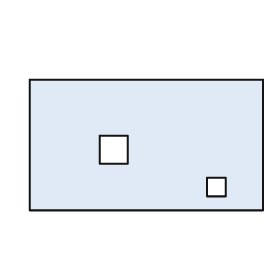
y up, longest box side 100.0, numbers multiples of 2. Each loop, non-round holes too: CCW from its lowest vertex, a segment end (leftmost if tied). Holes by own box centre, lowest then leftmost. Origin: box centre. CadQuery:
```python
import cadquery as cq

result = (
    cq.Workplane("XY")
    .moveTo(-50.0, -28.0)
    .lineTo(50.0, -28.0)
    .lineTo(50.0, 28.0)
    .lineTo(-50.0, 28.0)
    .close()
    .moveTo(26.0, -22.0)
    .lineTo(34.0, -22.0)
    .lineTo(34.0, -14.0)
    .lineTo(26.0, -14.0)
    .close()
    .moveTo(-20.0, -8.0)
    .lineTo(-8.0, -8.0)
    .lineTo(-8.0, 4.0)
    .lineTo(-20.0, 4.0)
    .close()
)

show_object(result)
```